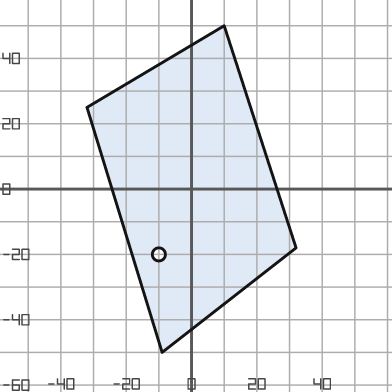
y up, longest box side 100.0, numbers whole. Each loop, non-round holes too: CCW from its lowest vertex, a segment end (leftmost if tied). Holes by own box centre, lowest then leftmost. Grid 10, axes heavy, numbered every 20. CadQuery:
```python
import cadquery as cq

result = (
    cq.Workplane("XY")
    .moveTo(-9.0, -50.0)
    .lineTo(32.0, -18.0)
    .lineTo(10.0, 50.0)
    .lineTo(-32.0, 25.0)
    .close()
    .moveTo(-10.0, -20.0)
    .circle(2.0)
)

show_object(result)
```